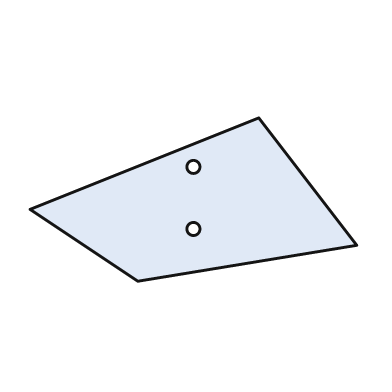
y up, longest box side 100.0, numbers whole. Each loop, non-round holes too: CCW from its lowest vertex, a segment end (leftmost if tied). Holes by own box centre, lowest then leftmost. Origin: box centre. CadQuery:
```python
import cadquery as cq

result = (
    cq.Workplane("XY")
    .moveTo(-17.0, -25.0)
    .lineTo(50.0, -14.0)
    .lineTo(20.0, 25.0)
    .lineTo(-50.0, -3.0)
    .close()
    .moveTo(0.0, -9.0)
    .circle(2.0)
    .moveTo(0.0, 10.0)
    .circle(2.0)
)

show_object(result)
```